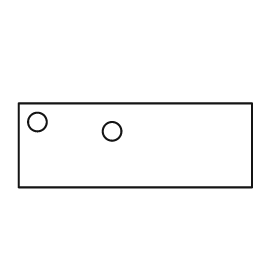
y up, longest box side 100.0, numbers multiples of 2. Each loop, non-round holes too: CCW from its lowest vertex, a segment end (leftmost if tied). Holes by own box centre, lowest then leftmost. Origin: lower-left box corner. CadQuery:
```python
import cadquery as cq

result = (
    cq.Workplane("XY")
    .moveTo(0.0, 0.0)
    .lineTo(100.0, 0.0)
    .lineTo(100.0, 36.0)
    .lineTo(0.0, 36.0)
    .close()
    .moveTo(40.0, 24.0)
    .circle(4.0)
    .moveTo(8.0, 28.0)
    .circle(4.0)
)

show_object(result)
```